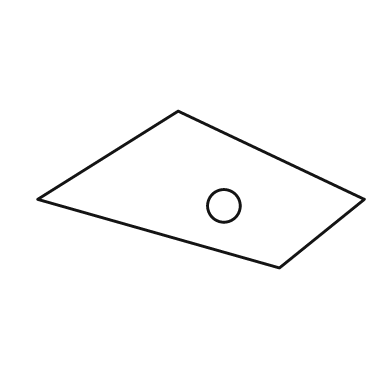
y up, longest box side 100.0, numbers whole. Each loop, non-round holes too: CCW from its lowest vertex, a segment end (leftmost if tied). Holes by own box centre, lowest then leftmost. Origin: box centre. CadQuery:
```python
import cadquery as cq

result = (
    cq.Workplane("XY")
    .moveTo(24.0, -24.0)
    .lineTo(50.0, -3.0)
    .lineTo(-7.0, 24.0)
    .lineTo(-50.0, -3.0)
    .close()
    .moveTo(7.0, -5.0)
    .circle(5.0)
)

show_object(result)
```